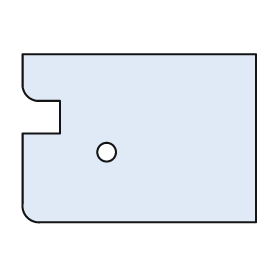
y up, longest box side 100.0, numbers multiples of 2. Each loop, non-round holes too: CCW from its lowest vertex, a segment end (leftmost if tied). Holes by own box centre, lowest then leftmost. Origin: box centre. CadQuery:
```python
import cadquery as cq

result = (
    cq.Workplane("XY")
    .moveTo(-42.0, -36.0)
    .lineTo(50.0, -36.0)
    .lineTo(50.0, 36.0)
    .lineTo(-50.0, 36.0)
    .lineTo(-50.0, 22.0)
    .threePointArc((-48.0, 18.0), (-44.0, 16.0))
    .lineTo(-34.0, 16.0)
    .lineTo(-34.0, 2.0)
    .lineTo(-50.0, 2.0)
    .lineTo(-50.0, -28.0)
    .threePointArc((-48.0, -34.0), (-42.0, -36.0))
    .close()
    .moveTo(-14.0, -6.0)
    .circle(4.0)
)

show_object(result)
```